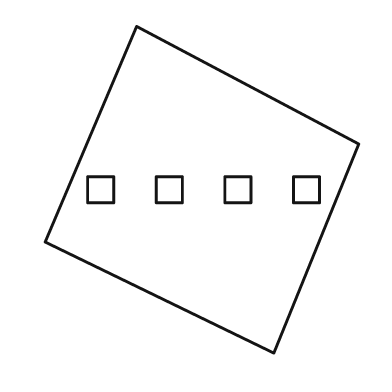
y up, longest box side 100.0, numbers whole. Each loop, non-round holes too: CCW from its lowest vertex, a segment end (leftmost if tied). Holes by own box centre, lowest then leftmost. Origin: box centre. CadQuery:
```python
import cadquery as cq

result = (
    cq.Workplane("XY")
    .moveTo(22.0, -50.0)
    .lineTo(48.0, 14.0)
    .lineTo(-20.0, 50.0)
    .lineTo(-48.0, -16.0)
    .close()
    .moveTo(-35.0, -4.0)
    .lineTo(-27.0, -4.0)
    .lineTo(-27.0, 4.0)
    .lineTo(-35.0, 4.0)
    .close()
    .moveTo(-14.0, -4.0)
    .lineTo(-6.0, -4.0)
    .lineTo(-6.0, 4.0)
    .lineTo(-14.0, 4.0)
    .close()
    .moveTo(7.0, -4.0)
    .lineTo(15.0, -4.0)
    .lineTo(15.0, 4.0)
    .lineTo(7.0, 4.0)
    .close()
    .moveTo(28.0, -4.0)
    .lineTo(36.0, -4.0)
    .lineTo(36.0, 4.0)
    .lineTo(28.0, 4.0)
    .close()
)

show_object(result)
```